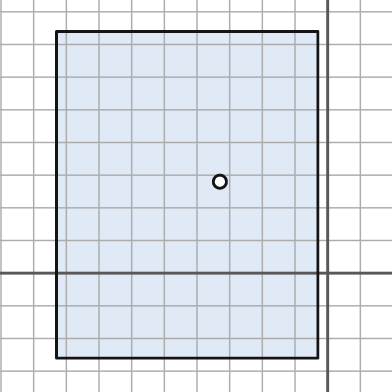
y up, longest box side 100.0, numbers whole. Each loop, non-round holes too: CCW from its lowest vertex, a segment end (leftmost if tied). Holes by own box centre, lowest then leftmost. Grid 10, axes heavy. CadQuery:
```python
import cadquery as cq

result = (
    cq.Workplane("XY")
    .moveTo(-83.0, -26.0)
    .lineTo(-3.0, -26.0)
    .lineTo(-3.0, 74.0)
    .lineTo(-83.0, 74.0)
    .close()
    .moveTo(-33.0, 28.0)
    .circle(2.0)
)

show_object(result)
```